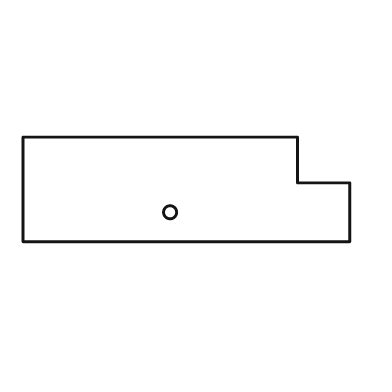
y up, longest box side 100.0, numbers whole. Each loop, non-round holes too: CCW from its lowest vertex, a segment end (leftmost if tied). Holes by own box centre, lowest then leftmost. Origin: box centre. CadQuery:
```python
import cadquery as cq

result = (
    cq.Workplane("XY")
    .moveTo(-50.0, -16.0)
    .lineTo(50.0, -16.0)
    .lineTo(50.0, 2.0)
    .lineTo(34.0, 2.0)
    .lineTo(34.0, 16.0)
    .lineTo(-50.0, 16.0)
    .close()
    .moveTo(-5.0, -7.0)
    .circle(2.0)
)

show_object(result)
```